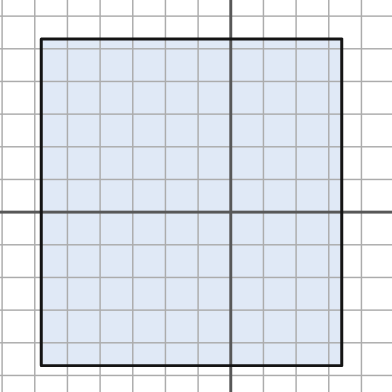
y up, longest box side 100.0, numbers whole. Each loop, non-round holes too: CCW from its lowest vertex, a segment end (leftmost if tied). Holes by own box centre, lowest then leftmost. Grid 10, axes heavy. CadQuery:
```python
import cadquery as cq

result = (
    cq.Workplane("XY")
    .moveTo(-58.0, -47.0)
    .lineTo(34.0, -47.0)
    .lineTo(34.0, 53.0)
    .lineTo(-58.0, 53.0)
    .close()
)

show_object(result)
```